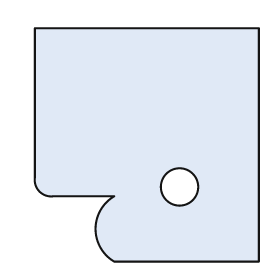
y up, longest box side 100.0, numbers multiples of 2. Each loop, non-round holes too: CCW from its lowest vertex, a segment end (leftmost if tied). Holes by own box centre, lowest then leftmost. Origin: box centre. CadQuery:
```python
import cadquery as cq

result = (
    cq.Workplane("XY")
    .moveTo(-14.0, -50.0)
    .lineTo(48.0, -50.0)
    .lineTo(48.0, 50.0)
    .lineTo(-48.0, 50.0)
    .lineTo(-48.0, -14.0)
    .threePointArc((-46.0, -20.0), (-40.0, -22.0))
    .lineTo(-14.0, -22.0)
    .threePointArc((-22.0, -36.0), (-14.0, -50.0))
    .close()
    .moveTo(14.0, -18.0)
    .circle(8.0)
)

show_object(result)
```